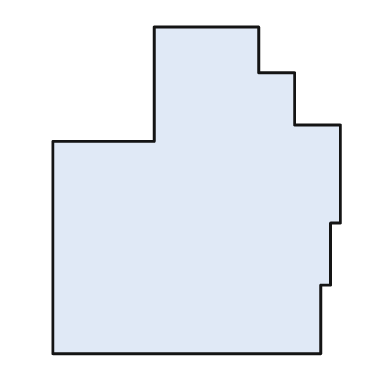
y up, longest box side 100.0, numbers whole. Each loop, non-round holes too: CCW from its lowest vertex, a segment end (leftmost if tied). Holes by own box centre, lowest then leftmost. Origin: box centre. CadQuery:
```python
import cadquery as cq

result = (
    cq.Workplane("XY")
    .moveTo(-44.0, -50.0)
    .lineTo(38.0, -50.0)
    .lineTo(38.0, -29.0)
    .lineTo(41.0, -29.0)
    .lineTo(41.0, -10.0)
    .lineTo(44.0, -10.0)
    .lineTo(44.0, 20.0)
    .lineTo(30.0, 20.0)
    .lineTo(30.0, 36.0)
    .lineTo(19.0, 36.0)
    .lineTo(19.0, 50.0)
    .lineTo(-13.0, 50.0)
    .lineTo(-13.0, 15.0)
    .lineTo(-44.0, 15.0)
    .close()
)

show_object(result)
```